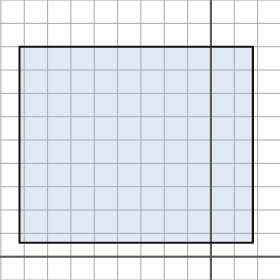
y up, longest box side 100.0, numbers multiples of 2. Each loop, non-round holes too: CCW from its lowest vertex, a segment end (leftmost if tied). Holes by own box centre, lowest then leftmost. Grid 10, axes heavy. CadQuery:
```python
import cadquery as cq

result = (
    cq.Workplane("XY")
    .moveTo(-82.0, 6.0)
    .lineTo(18.0, 6.0)
    .lineTo(18.0, 90.0)
    .lineTo(-82.0, 90.0)
    .close()
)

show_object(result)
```